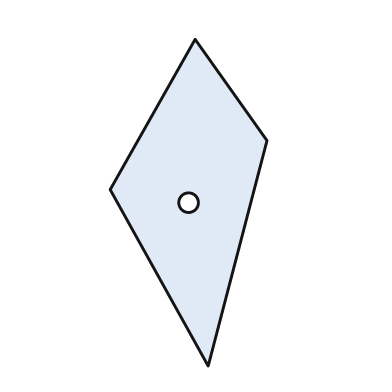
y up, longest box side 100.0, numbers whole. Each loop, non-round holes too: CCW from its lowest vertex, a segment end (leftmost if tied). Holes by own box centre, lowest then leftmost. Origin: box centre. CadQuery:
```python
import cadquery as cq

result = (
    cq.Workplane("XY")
    .moveTo(6.0, -50.0)
    .lineTo(24.0, 19.0)
    .lineTo(2.0, 50.0)
    .lineTo(-24.0, 4.0)
    .close()
    .moveTo(0.0, 0.0)
    .circle(3.0)
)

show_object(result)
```